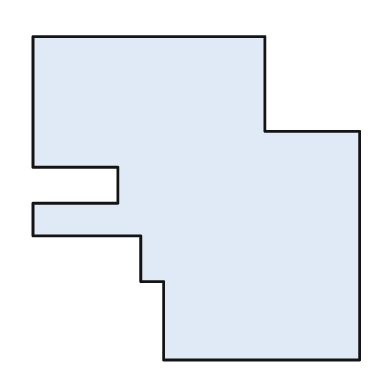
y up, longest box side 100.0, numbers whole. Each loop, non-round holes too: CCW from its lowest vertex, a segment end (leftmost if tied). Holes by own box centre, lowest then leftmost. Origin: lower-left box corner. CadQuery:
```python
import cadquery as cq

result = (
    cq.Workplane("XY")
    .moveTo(40.0, 0.0)
    .lineTo(100.0, 0.0)
    .lineTo(100.0, 70.0)
    .lineTo(71.0, 70.0)
    .lineTo(71.0, 99.0)
    .lineTo(0.0, 99.0)
    .lineTo(0.0, 59.0)
    .lineTo(26.0, 59.0)
    .lineTo(26.0, 48.0)
    .lineTo(0.0, 48.0)
    .lineTo(0.0, 38.0)
    .lineTo(33.0, 38.0)
    .lineTo(33.0, 24.0)
    .lineTo(40.0, 24.0)
    .close()
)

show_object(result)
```